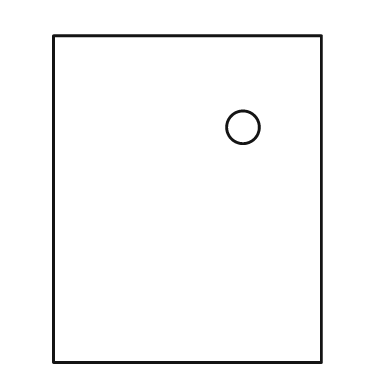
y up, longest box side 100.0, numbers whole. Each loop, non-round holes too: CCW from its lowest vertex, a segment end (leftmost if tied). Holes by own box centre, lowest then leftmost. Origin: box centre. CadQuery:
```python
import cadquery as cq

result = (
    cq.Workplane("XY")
    .moveTo(-41.0, -50.0)
    .lineTo(41.0, -50.0)
    .lineTo(41.0, 50.0)
    .lineTo(-41.0, 50.0)
    .close()
    .moveTo(17.0, 22.0)
    .circle(5.0)
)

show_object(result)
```